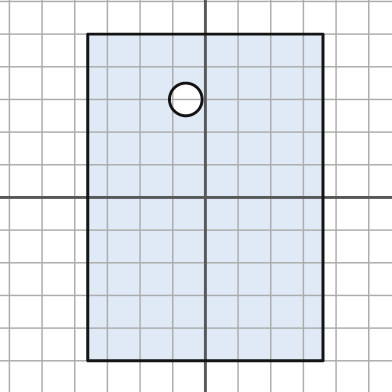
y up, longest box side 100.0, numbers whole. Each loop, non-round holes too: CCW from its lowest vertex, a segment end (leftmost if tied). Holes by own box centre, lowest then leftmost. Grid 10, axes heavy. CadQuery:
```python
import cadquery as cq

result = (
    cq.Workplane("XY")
    .moveTo(-36.0, -50.0)
    .lineTo(36.0, -50.0)
    .lineTo(36.0, 50.0)
    .lineTo(-36.0, 50.0)
    .close()
    .moveTo(-6.0, 30.0)
    .circle(5.0)
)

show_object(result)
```